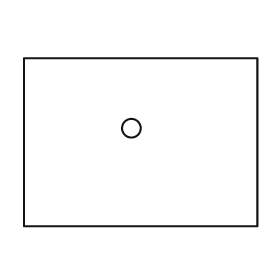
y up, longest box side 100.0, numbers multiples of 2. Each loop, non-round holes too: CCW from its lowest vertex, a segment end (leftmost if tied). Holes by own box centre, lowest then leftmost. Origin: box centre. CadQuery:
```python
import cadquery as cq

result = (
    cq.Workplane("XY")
    .moveTo(-50.0, -36.0)
    .lineTo(50.0, -36.0)
    .lineTo(50.0, 36.0)
    .lineTo(-50.0, 36.0)
    .close()
    .moveTo(-4.0, 6.0)
    .circle(4.0)
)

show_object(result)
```